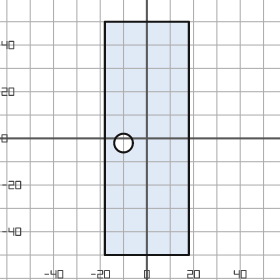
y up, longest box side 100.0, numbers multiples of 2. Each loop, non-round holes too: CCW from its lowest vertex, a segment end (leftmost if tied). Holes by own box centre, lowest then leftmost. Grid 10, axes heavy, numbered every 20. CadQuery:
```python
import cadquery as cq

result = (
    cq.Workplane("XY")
    .moveTo(-18.0, -50.0)
    .lineTo(18.0, -50.0)
    .lineTo(18.0, 50.0)
    .lineTo(-18.0, 50.0)
    .close()
    .moveTo(-10.0, -2.0)
    .circle(4.0)
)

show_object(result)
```